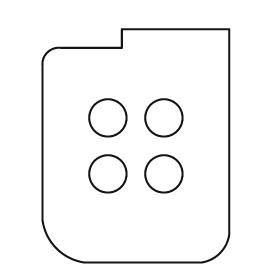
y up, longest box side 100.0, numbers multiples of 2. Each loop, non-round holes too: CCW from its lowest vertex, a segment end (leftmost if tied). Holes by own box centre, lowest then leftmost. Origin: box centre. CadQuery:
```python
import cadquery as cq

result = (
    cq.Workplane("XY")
    .moveTo(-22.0, -50.0)
    .lineTo(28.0, -50.0)
    .threePointArc((36.0, -46.0), (40.0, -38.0))
    .lineTo(40.0, 50.0)
    .lineTo(-6.0, 50.0)
    .lineTo(-6.0, 42.0)
    .lineTo(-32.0, 42.0)
    .threePointArc((-38.0, 40.0), (-40.0, 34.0))
    .lineTo(-40.0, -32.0)
    .threePointArc((-34.0, -44.0), (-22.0, -50.0))
    .close()
    .moveTo(-12.0, -12.0)
    .circle(8.0)
    .moveTo(12.0, -12.0)
    .circle(8.0)
    .moveTo(-12.0, 12.0)
    .circle(8.0)
    .moveTo(12.0, 12.0)
    .circle(8.0)
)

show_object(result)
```